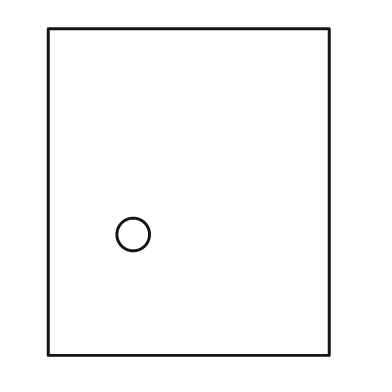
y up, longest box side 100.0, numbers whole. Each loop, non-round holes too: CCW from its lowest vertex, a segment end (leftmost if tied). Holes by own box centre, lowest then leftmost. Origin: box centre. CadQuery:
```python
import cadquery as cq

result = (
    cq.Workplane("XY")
    .moveTo(-43.0, -50.0)
    .lineTo(43.0, -50.0)
    .lineTo(43.0, 50.0)
    .lineTo(-43.0, 50.0)
    .close()
    .moveTo(-17.0, -13.0)
    .circle(5.0)
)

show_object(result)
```